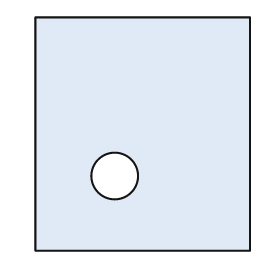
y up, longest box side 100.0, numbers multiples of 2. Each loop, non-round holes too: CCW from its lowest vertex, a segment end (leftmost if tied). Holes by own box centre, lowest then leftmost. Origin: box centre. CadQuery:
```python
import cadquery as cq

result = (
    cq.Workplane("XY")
    .moveTo(-46.0, -50.0)
    .lineTo(46.0, -50.0)
    .lineTo(46.0, 50.0)
    .lineTo(-46.0, 50.0)
    .close()
    .moveTo(-12.0, -18.0)
    .circle(10.0)
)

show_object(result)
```